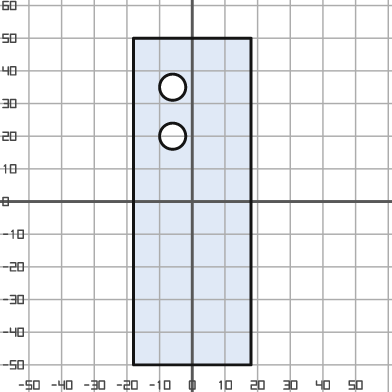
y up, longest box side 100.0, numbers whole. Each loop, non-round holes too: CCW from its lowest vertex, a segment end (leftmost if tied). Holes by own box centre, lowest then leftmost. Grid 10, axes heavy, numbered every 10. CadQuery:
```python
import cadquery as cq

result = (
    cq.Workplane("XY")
    .moveTo(-18.0, -50.0)
    .lineTo(18.0, -50.0)
    .lineTo(18.0, 50.0)
    .lineTo(-18.0, 50.0)
    .close()
    .moveTo(-6.0, 20.0)
    .circle(4.0)
    .moveTo(-6.0, 35.0)
    .circle(4.0)
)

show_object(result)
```